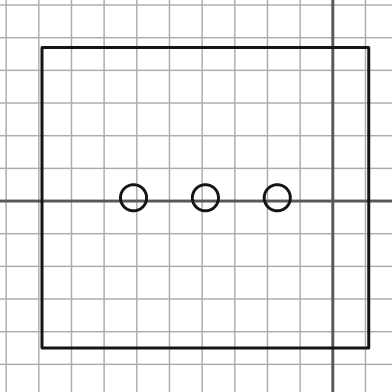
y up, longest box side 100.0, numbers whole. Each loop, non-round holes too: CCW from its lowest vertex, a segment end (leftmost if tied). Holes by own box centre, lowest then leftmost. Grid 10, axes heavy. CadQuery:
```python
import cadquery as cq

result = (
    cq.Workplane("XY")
    .moveTo(-89.0, -45.0)
    .lineTo(11.0, -45.0)
    .lineTo(11.0, 47.0)
    .lineTo(-89.0, 47.0)
    .close()
    .moveTo(-61.0, 1.0)
    .circle(4.0)
    .moveTo(-39.0, 1.0)
    .circle(4.0)
    .moveTo(-17.0, 1.0)
    .circle(4.0)
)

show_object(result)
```